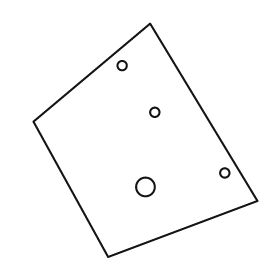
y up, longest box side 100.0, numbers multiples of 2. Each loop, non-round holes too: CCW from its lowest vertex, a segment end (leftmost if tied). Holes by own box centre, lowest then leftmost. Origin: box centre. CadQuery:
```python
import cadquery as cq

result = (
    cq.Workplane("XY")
    .moveTo(-16.0, -50.0)
    .lineTo(48.0, -26.0)
    .lineTo(2.0, 50.0)
    .lineTo(-48.0, 8.0)
    .close()
    .moveTo(0.0, -20.0)
    .circle(4.0)
    .moveTo(34.0, -14.0)
    .circle(2.0)
    .moveTo(4.0, 12.0)
    .circle(2.0)
    .moveTo(-10.0, 32.0)
    .circle(2.0)
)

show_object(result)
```